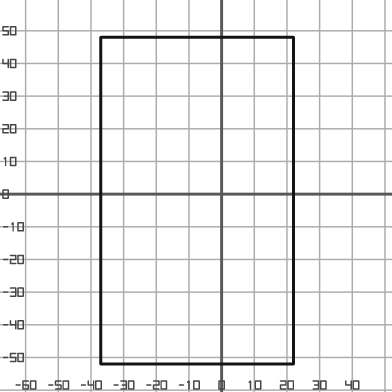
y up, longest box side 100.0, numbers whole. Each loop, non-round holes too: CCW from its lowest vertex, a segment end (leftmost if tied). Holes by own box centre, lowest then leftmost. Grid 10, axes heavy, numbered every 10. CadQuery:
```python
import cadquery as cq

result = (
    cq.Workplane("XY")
    .moveTo(-37.0, -52.0)
    .lineTo(22.0, -52.0)
    .lineTo(22.0, 48.0)
    .lineTo(-37.0, 48.0)
    .close()
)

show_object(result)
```